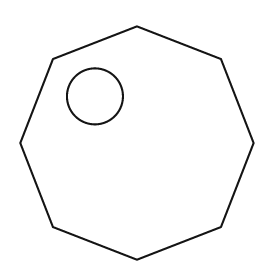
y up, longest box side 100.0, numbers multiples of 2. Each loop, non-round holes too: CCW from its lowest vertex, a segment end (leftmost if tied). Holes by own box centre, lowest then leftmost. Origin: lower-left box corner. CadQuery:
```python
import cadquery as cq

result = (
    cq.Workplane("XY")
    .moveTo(50.0, 0.0)
    .lineTo(86.0, 14.0)
    .lineTo(100.0, 50.0)
    .lineTo(86.0, 86.0)
    .lineTo(50.0, 100.0)
    .lineTo(14.0, 86.0)
    .lineTo(0.0, 50.0)
    .lineTo(14.0, 14.0)
    .close()
    .moveTo(32.0, 70.0)
    .circle(12.0)
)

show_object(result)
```